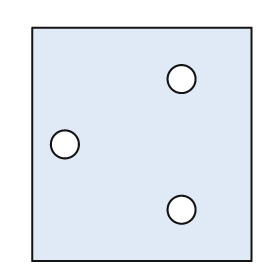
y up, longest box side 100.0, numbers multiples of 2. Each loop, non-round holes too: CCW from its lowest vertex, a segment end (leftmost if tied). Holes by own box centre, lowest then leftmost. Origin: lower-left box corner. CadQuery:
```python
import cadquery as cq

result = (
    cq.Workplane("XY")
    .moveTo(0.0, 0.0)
    .lineTo(94.0, 0.0)
    .lineTo(94.0, 100.0)
    .lineTo(0.0, 100.0)
    .close()
    .moveTo(64.0, 22.0)
    .circle(6.0)
    .moveTo(14.0, 50.0)
    .circle(6.0)
    .moveTo(64.0, 78.0)
    .circle(6.0)
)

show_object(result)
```